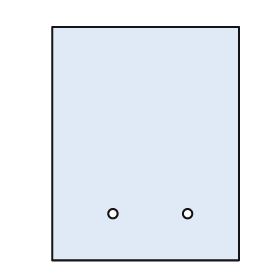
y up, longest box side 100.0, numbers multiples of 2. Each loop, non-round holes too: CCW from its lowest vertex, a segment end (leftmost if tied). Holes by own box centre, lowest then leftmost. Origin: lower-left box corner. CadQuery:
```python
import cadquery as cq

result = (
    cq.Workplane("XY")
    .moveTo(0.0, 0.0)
    .lineTo(80.0, 0.0)
    .lineTo(80.0, 100.0)
    .lineTo(0.0, 100.0)
    .close()
    .moveTo(26.0, 20.0)
    .circle(2.0)
    .moveTo(58.0, 20.0)
    .circle(2.0)
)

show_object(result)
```